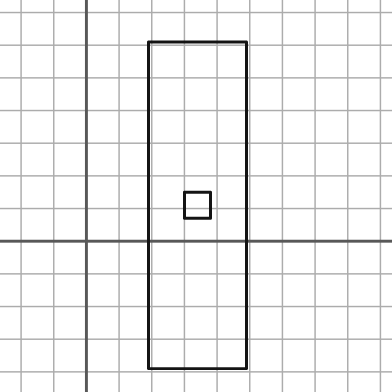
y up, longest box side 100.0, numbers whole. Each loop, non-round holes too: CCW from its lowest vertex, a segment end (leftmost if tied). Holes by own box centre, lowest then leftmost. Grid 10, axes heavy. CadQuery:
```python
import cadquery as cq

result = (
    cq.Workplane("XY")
    .moveTo(19.0, -39.0)
    .lineTo(49.0, -39.0)
    .lineTo(49.0, 61.0)
    .lineTo(19.0, 61.0)
    .close()
    .moveTo(30.0, 7.0)
    .lineTo(38.0, 7.0)
    .lineTo(38.0, 15.0)
    .lineTo(30.0, 15.0)
    .close()
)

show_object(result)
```